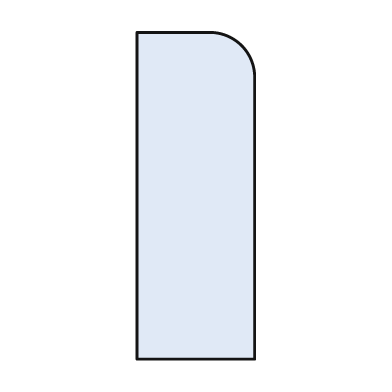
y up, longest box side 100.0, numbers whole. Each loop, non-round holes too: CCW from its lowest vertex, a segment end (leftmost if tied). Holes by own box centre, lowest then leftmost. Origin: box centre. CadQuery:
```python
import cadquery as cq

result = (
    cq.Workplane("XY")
    .moveTo(-18.0, -50.0)
    .lineTo(18.0, -50.0)
    .lineTo(18.0, 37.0)
    .threePointArc((14.0, 46.0), (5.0, 50.0))
    .lineTo(-18.0, 50.0)
    .close()
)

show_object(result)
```